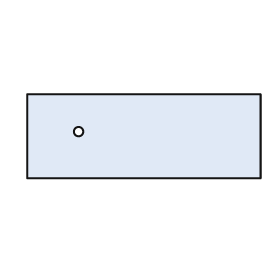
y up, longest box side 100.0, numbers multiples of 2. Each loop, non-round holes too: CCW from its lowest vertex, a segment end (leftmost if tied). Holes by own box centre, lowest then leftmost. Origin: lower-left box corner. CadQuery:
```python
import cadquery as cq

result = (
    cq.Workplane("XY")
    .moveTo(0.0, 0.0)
    .lineTo(100.0, 0.0)
    .lineTo(100.0, 36.0)
    .lineTo(0.0, 36.0)
    .close()
    .moveTo(22.0, 20.0)
    .circle(2.0)
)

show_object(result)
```